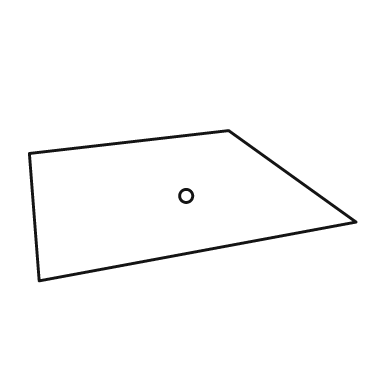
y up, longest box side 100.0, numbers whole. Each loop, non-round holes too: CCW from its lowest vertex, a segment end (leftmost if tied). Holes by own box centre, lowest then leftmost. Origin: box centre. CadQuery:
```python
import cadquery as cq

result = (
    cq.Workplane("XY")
    .moveTo(-47.0, -23.0)
    .lineTo(50.0, -5.0)
    .lineTo(11.0, 23.0)
    .lineTo(-50.0, 16.0)
    .close()
    .moveTo(-2.0, 3.0)
    .circle(2.0)
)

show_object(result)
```